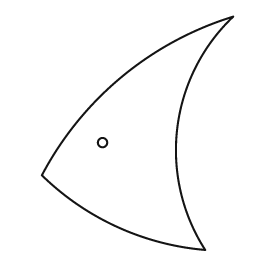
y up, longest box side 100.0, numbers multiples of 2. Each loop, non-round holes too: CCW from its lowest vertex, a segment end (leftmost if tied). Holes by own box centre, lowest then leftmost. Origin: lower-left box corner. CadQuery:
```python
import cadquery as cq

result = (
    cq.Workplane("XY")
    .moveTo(70.0, 0.0)
    .threePointArc((58.0, 52.0), (82.0, 100.0))
    .threePointArc((34.0, 74.0), (0.0, 32.0))
    .threePointArc((32.0, 10.0), (70.0, 0.0))
    .close()
    .moveTo(26.0, 46.0)
    .circle(2.0)
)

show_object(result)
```